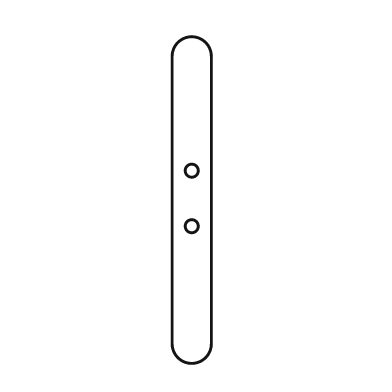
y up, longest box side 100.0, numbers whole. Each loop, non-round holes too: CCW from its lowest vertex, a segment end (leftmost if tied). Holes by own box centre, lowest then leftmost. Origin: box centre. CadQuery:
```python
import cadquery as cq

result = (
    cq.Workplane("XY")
    .moveTo(-6.0, -44.0)
    .threePointArc((0.0, -50.0), (6.0, -44.0))
    .lineTo(6.0, 44.0)
    .threePointArc((0.0, 50.0), (-6.0, 44.0))
    .close()
    .moveTo(0.0, -8.0)
    .circle(2.0)
    .moveTo(0.0, 9.0)
    .circle(2.0)
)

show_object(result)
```